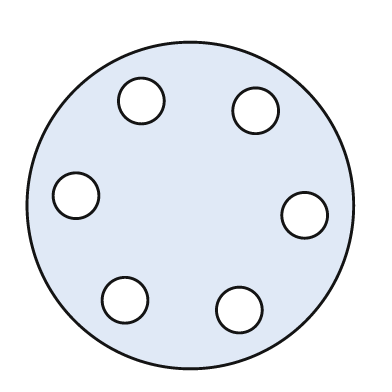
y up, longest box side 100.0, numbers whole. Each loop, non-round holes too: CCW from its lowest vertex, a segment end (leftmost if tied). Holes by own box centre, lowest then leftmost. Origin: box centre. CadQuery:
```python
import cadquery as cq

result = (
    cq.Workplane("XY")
    .moveTo(0.0, 0.0)
    .circle(50.0)
    .moveTo(15.0, -32.0)
    .circle(7.0)
    .moveTo(-20.0, -29.0)
    .circle(7.0)
    .moveTo(35.0, -3.0)
    .circle(7.0)
    .moveTo(-35.0, 3.0)
    .circle(7.0)
    .moveTo(20.0, 29.0)
    .circle(7.0)
    .moveTo(-15.0, 32.0)
    .circle(7.0)
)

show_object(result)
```